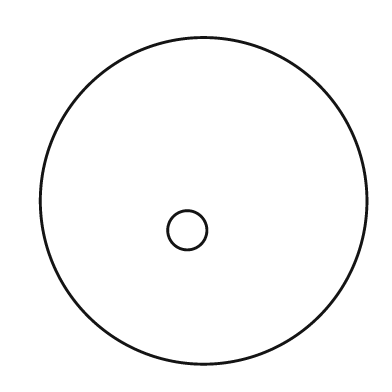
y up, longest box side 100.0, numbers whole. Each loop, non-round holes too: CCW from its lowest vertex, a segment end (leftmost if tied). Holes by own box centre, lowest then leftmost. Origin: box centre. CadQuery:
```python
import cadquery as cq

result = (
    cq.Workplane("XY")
    .moveTo(0.0, 0.0)
    .circle(50.0)
    .moveTo(-5.0, -9.0)
    .circle(6.0)
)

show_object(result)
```